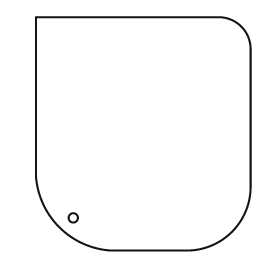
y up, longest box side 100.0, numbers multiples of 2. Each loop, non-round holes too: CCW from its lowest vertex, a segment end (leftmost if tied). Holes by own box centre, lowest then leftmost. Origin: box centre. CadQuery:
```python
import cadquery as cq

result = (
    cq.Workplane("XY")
    .moveTo(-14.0, -50.0)
    .lineTo(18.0, -50.0)
    .threePointArc((38.0, -42.0), (46.0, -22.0))
    .lineTo(46.0, 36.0)
    .threePointArc((42.0, 46.0), (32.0, 50.0))
    .lineTo(-46.0, 50.0)
    .lineTo(-46.0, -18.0)
    .threePointArc((-36.0, -40.0), (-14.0, -50.0))
    .close()
    .moveTo(-30.0, -36.0)
    .circle(2.0)
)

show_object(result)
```